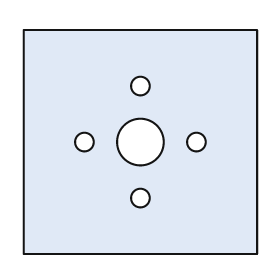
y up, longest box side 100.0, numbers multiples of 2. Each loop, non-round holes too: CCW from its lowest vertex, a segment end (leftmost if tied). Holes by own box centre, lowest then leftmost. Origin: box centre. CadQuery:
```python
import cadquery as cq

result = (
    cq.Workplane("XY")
    .moveTo(-50.0, -48.0)
    .lineTo(50.0, -48.0)
    .lineTo(50.0, 48.0)
    .lineTo(-50.0, 48.0)
    .close()
    .moveTo(0.0, -24.0)
    .circle(4.0)
    .moveTo(-24.0, 0.0)
    .circle(4.0)
    .moveTo(0.0, 0.0)
    .circle(10.0)
    .moveTo(24.0, 0.0)
    .circle(4.0)
    .moveTo(0.0, 24.0)
    .circle(4.0)
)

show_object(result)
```